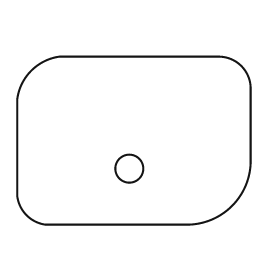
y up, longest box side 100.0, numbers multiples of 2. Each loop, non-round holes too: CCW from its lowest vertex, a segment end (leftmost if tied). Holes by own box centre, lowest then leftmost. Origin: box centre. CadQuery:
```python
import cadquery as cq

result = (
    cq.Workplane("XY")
    .moveTo(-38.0, -36.0)
    .lineTo(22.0, -36.0)
    .threePointArc((42.0, -28.0), (50.0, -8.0))
    .lineTo(50.0, 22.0)
    .threePointArc((46.0, 32.0), (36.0, 36.0))
    .lineTo(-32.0, 36.0)
    .threePointArc((-44.0, 30.0), (-50.0, 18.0))
    .lineTo(-50.0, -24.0)
    .threePointArc((-46.0, -32.0), (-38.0, -36.0))
    .close()
    .moveTo(-2.0, -12.0)
    .circle(6.0)
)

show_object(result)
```